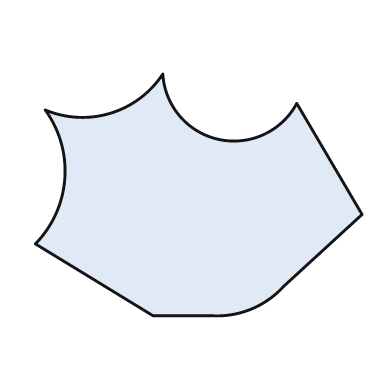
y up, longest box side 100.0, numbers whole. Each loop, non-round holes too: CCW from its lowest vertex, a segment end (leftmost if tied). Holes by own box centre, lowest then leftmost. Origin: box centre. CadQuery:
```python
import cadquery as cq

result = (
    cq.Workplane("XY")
    .moveTo(-14.0, -37.0)
    .lineTo(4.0, -37.0)
    .threePointArc((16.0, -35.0), (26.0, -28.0))
    .lineTo(50.0, -6.0)
    .lineTo(30.0, 28.0)
    .threePointArc((6.0, 17.0), (-11.0, 37.0))
    .threePointArc((-27.0, 25.0), (-47.0, 26.0))
    .threePointArc((-41.0, 5.0), (-50.0, -15.0))
    .close()
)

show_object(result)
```